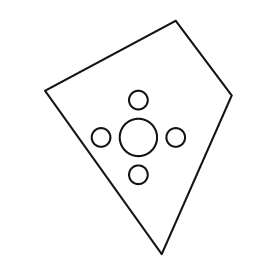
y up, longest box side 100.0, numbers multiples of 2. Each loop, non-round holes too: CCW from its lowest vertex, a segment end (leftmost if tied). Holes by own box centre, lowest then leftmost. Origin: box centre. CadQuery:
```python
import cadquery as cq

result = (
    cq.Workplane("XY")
    .moveTo(10.0, -50.0)
    .lineTo(40.0, 18.0)
    .lineTo(16.0, 50.0)
    .lineTo(-40.0, 20.0)
    .close()
    .moveTo(0.0, -16.0)
    .circle(4.0)
    .moveTo(-16.0, 0.0)
    .circle(4.0)
    .moveTo(0.0, 0.0)
    .circle(8.0)
    .moveTo(16.0, 0.0)
    .circle(4.0)
    .moveTo(0.0, 16.0)
    .circle(4.0)
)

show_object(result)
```